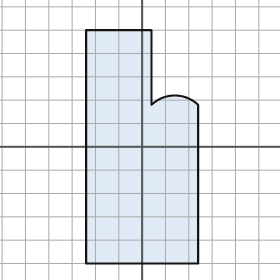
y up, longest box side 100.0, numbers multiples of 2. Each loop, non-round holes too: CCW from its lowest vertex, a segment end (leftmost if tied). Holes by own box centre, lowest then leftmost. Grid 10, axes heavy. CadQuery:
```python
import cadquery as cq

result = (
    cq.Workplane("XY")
    .moveTo(-24.0, -50.0)
    .lineTo(24.0, -50.0)
    .lineTo(24.0, 18.0)
    .threePointArc((14.0, 22.0), (4.0, 18.0))
    .lineTo(4.0, 50.0)
    .lineTo(-24.0, 50.0)
    .close()
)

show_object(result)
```